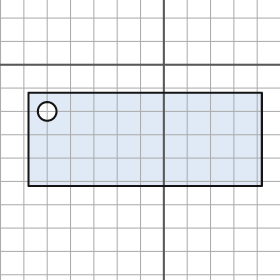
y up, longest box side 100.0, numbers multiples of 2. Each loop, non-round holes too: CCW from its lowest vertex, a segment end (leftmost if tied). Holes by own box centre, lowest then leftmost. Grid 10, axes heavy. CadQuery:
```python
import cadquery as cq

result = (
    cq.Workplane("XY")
    .moveTo(-58.0, -52.0)
    .lineTo(42.0, -52.0)
    .lineTo(42.0, -12.0)
    .lineTo(-58.0, -12.0)
    .close()
    .moveTo(-50.0, -20.0)
    .circle(4.0)
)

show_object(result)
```